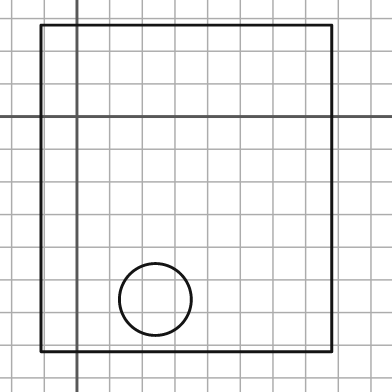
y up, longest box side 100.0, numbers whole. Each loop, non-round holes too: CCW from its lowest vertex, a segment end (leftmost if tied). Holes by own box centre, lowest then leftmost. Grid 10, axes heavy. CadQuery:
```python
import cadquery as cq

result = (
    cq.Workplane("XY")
    .moveTo(-11.0, -72.0)
    .lineTo(78.0, -72.0)
    .lineTo(78.0, 28.0)
    .lineTo(-11.0, 28.0)
    .close()
    .moveTo(24.0, -56.0)
    .circle(11.0)
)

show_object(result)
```